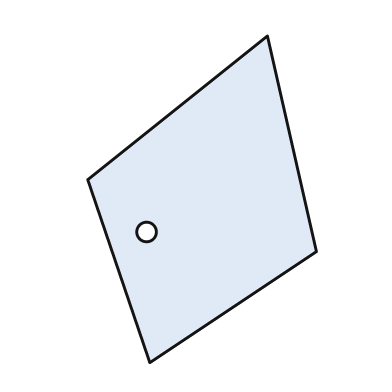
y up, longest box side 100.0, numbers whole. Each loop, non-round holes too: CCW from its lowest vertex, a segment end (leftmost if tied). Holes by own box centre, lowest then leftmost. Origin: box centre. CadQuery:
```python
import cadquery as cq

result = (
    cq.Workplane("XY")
    .moveTo(-16.0, -50.0)
    .lineTo(35.0, -16.0)
    .lineTo(20.0, 50.0)
    .lineTo(-35.0, 6.0)
    .close()
    .moveTo(-17.0, -10.0)
    .circle(3.0)
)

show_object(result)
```